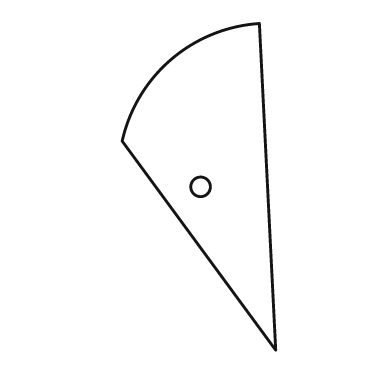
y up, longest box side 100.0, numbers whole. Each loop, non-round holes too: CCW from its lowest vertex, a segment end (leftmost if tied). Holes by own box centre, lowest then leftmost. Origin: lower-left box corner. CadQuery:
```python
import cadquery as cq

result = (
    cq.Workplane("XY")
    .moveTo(47.0, 0.0)
    .lineTo(42.0, 100.0)
    .threePointArc((15.0, 89.0), (0.0, 64.0))
    .close()
    .moveTo(24.0, 50.0)
    .circle(3.0)
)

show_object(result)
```